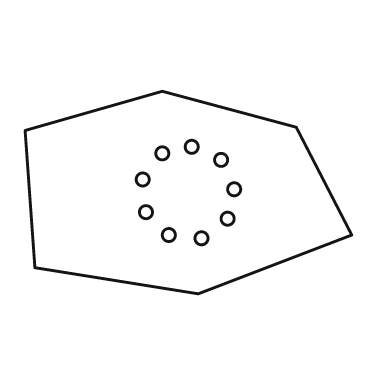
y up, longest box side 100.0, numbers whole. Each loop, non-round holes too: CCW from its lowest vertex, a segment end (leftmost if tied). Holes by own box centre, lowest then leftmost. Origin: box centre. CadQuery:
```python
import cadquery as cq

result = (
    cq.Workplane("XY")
    .moveTo(3.0, -31.0)
    .lineTo(50.0, -13.0)
    .lineTo(33.0, 20.0)
    .lineTo(-8.0, 31.0)
    .lineTo(-50.0, 19.0)
    .lineTo(-47.0, -23.0)
    .close()
    .moveTo(4.0, -14.0)
    .circle(2.0)
    .moveTo(-6.0, -13.0)
    .circle(2.0)
    .moveTo(12.0, -8.0)
    .circle(2.0)
    .moveTo(-13.0, -6.0)
    .circle(2.0)
    .moveTo(14.0, 1.0)
    .circle(2.0)
    .moveTo(-14.0, 4.0)
    .circle(2.0)
    .moveTo(10.0, 10.0)
    .circle(2.0)
    .moveTo(-8.0, 12.0)
    .circle(2.0)
    .moveTo(1.0, 14.0)
    .circle(2.0)
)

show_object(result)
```